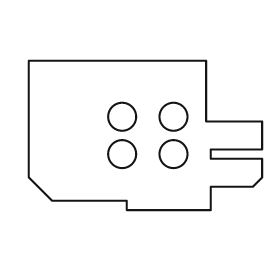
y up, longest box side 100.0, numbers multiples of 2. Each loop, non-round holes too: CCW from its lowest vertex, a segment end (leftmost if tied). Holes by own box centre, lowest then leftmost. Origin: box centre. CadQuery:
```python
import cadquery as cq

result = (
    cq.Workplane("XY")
    .moveTo(-8.0, -32.0)
    .lineTo(28.0, -32.0)
    .lineTo(28.0, -22.0)
    .lineTo(46.0, -22.0)
    .lineTo(50.0, -18.0)
    .lineTo(50.0, -10.0)
    .lineTo(28.0, -10.0)
    .lineTo(28.0, -6.0)
    .lineTo(50.0, -6.0)
    .lineTo(50.0, 6.0)
    .lineTo(26.0, 6.0)
    .lineTo(26.0, 32.0)
    .lineTo(-50.0, 32.0)
    .lineTo(-50.0, -18.0)
    .lineTo(-40.0, -28.0)
    .lineTo(-8.0, -28.0)
    .close()
    .moveTo(-10.0, -8.0)
    .circle(6.0)
    .moveTo(12.0, -8.0)
    .circle(6.0)
    .moveTo(-10.0, 8.0)
    .circle(6.0)
    .moveTo(12.0, 8.0)
    .circle(6.0)
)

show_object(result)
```